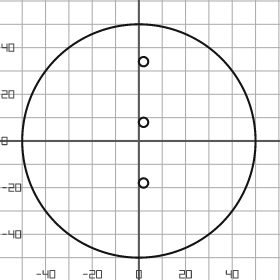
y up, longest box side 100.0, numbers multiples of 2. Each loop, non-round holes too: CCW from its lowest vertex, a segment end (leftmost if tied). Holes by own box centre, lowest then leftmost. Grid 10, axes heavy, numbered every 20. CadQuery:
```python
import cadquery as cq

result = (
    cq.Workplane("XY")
    .moveTo(0.0, 0.0)
    .circle(50.0)
    .moveTo(2.0, -18.0)
    .circle(2.0)
    .moveTo(2.0, 8.0)
    .circle(2.0)
    .moveTo(2.0, 34.0)
    .circle(2.0)
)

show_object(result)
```